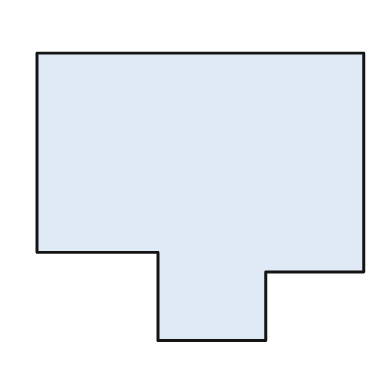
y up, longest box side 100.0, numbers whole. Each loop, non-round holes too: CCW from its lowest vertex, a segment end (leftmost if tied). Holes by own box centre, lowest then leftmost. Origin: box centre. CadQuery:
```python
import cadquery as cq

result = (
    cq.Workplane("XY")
    .moveTo(-13.0, -44.0)
    .lineTo(20.0, -44.0)
    .lineTo(20.0, -23.0)
    .lineTo(50.0, -23.0)
    .lineTo(50.0, 44.0)
    .lineTo(-50.0, 44.0)
    .lineTo(-50.0, -17.0)
    .lineTo(-13.0, -17.0)
    .close()
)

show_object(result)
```